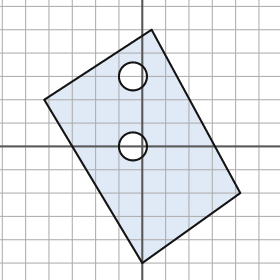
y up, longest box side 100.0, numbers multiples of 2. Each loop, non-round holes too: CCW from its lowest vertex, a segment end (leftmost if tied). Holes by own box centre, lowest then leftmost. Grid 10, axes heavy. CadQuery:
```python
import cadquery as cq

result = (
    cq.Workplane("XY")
    .moveTo(0.0, -50.0)
    .lineTo(42.0, -20.0)
    .lineTo(4.0, 50.0)
    .lineTo(-42.0, 20.0)
    .close()
    .moveTo(-4.0, 0.0)
    .circle(6.0)
    .moveTo(-4.0, 30.0)
    .circle(6.0)
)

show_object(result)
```